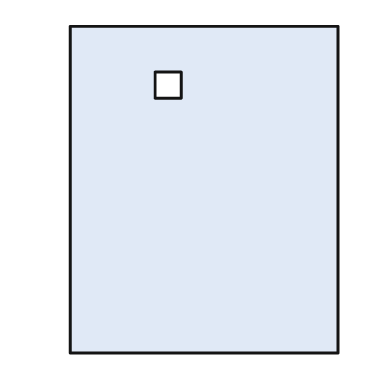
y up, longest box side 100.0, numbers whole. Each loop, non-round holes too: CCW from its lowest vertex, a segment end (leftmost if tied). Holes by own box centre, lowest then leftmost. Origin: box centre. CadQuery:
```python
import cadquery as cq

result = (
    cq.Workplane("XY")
    .moveTo(-41.0, -50.0)
    .lineTo(41.0, -50.0)
    .lineTo(41.0, 50.0)
    .lineTo(-41.0, 50.0)
    .close()
    .moveTo(-15.0, 28.0)
    .lineTo(-7.0, 28.0)
    .lineTo(-7.0, 36.0)
    .lineTo(-15.0, 36.0)
    .close()
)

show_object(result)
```